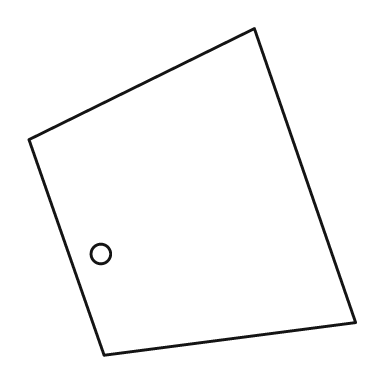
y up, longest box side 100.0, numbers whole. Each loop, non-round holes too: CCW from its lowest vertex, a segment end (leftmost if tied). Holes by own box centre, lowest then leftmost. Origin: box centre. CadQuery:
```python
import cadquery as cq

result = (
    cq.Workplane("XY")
    .moveTo(-27.0, -50.0)
    .lineTo(50.0, -40.0)
    .lineTo(19.0, 50.0)
    .lineTo(-50.0, 16.0)
    .close()
    .moveTo(-28.0, -19.0)
    .circle(3.0)
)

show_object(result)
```